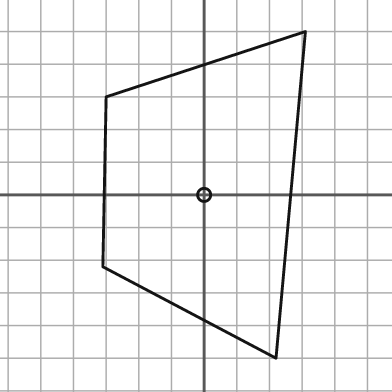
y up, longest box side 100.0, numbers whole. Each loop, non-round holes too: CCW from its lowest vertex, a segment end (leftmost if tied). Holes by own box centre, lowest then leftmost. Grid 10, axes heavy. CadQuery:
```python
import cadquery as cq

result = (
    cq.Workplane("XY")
    .moveTo(22.0, -50.0)
    .lineTo(31.0, 50.0)
    .lineTo(-30.0, 30.0)
    .lineTo(-31.0, -22.0)
    .close()
    .moveTo(0.0, 0.0)
    .circle(2.0)
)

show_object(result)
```